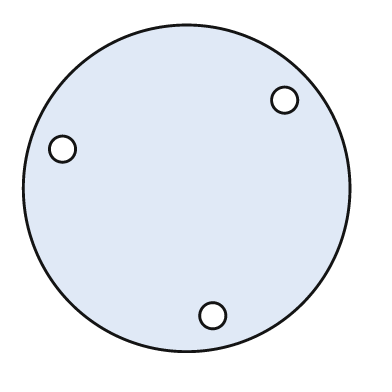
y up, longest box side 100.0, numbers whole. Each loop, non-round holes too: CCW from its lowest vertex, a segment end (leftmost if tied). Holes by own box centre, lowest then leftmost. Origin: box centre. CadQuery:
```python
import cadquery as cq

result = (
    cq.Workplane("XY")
    .moveTo(0.0, 0.0)
    .circle(50.0)
    .moveTo(8.0, -39.0)
    .circle(4.0)
    .moveTo(-38.0, 12.0)
    .circle(4.0)
    .moveTo(30.0, 27.0)
    .circle(4.0)
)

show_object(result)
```